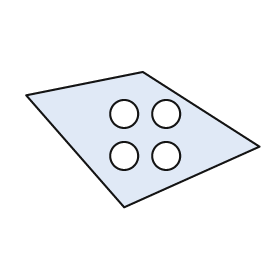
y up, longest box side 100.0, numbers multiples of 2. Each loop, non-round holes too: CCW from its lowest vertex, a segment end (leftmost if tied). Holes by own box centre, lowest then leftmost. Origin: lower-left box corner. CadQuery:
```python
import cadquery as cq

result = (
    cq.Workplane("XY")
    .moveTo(42.0, 0.0)
    .lineTo(100.0, 26.0)
    .lineTo(50.0, 58.0)
    .lineTo(0.0, 48.0)
    .close()
    .moveTo(42.0, 22.0)
    .circle(6.0)
    .moveTo(60.0, 22.0)
    .circle(6.0)
    .moveTo(42.0, 40.0)
    .circle(6.0)
    .moveTo(60.0, 40.0)
    .circle(6.0)
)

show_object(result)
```